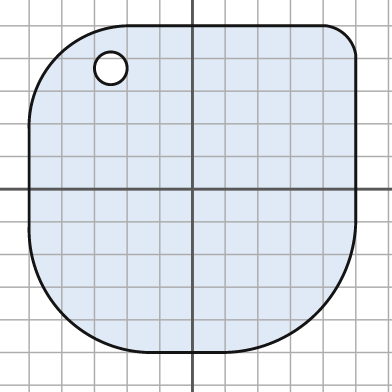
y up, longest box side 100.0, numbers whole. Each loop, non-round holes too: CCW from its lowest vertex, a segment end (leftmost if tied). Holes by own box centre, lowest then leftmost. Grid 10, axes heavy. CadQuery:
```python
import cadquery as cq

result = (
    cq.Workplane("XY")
    .moveTo(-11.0, -50.0)
    .lineTo(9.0, -50.0)
    .threePointArc((38.0, -38.0), (50.0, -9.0))
    .lineTo(50.0, 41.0)
    .threePointArc((47.0, 47.0), (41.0, 50.0))
    .lineTo(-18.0, 50.0)
    .threePointArc((-41.0, 41.0), (-50.0, 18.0))
    .lineTo(-50.0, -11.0)
    .threePointArc((-39.0, -39.0), (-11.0, -50.0))
    .close()
    .moveTo(-25.0, 37.0)
    .circle(5.0)
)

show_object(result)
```